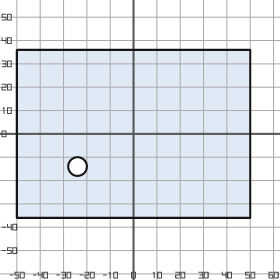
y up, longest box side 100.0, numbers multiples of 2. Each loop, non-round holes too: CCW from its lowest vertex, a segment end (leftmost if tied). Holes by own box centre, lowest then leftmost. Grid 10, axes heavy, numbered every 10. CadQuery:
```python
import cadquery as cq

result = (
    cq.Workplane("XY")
    .moveTo(-50.0, -36.0)
    .lineTo(50.0, -36.0)
    .lineTo(50.0, 36.0)
    .lineTo(-50.0, 36.0)
    .close()
    .moveTo(-24.0, -14.0)
    .circle(4.0)
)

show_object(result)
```